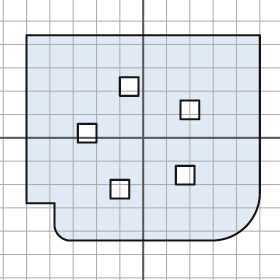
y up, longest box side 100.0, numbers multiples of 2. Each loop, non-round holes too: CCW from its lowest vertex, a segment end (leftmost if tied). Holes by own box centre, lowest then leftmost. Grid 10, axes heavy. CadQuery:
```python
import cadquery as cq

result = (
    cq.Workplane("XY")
    .moveTo(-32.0, -44.0)
    .lineTo(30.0, -44.0)
    .threePointArc((44.0, -38.0), (50.0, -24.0))
    .lineTo(50.0, 44.0)
    .lineTo(-50.0, 44.0)
    .lineTo(-50.0, -28.0)
    .lineTo(-38.0, -28.0)
    .lineTo(-38.0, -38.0)
    .threePointArc((-36.0, -42.0), (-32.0, -44.0))
    .close()
    .moveTo(-14.0, -26.0)
    .lineTo(-6.0, -26.0)
    .lineTo(-6.0, -18.0)
    .lineTo(-14.0, -18.0)
    .close()
    .moveTo(14.0, -20.0)
    .lineTo(22.0, -20.0)
    .lineTo(22.0, -12.0)
    .lineTo(14.0, -12.0)
    .close()
    .moveTo(-28.0, -2.0)
    .lineTo(-20.0, -2.0)
    .lineTo(-20.0, 6.0)
    .lineTo(-28.0, 6.0)
    .close()
    .moveTo(16.0, 8.0)
    .lineTo(24.0, 8.0)
    .lineTo(24.0, 16.0)
    .lineTo(16.0, 16.0)
    .close()
    .moveTo(-10.0, 18.0)
    .lineTo(-2.0, 18.0)
    .lineTo(-2.0, 26.0)
    .lineTo(-10.0, 26.0)
    .close()
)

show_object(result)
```